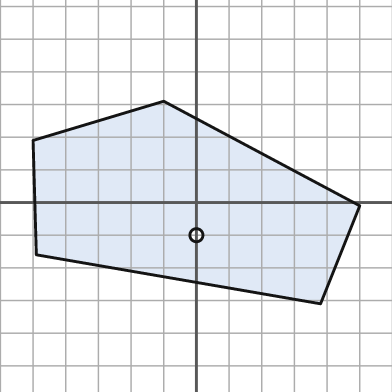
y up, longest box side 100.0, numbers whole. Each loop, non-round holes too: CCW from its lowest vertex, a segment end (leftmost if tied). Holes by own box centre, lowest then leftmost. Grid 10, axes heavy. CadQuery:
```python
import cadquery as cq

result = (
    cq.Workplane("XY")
    .moveTo(38.0, -31.0)
    .lineTo(50.0, -1.0)
    .lineTo(-10.0, 31.0)
    .lineTo(-50.0, 19.0)
    .lineTo(-49.0, -16.0)
    .close()
    .moveTo(0.0, -10.0)
    .circle(2.0)
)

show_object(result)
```